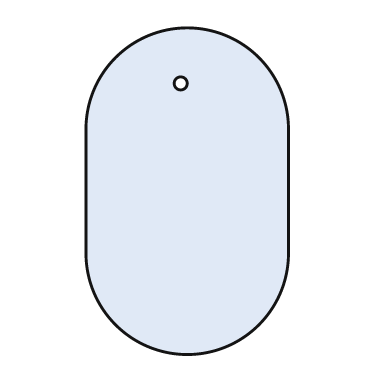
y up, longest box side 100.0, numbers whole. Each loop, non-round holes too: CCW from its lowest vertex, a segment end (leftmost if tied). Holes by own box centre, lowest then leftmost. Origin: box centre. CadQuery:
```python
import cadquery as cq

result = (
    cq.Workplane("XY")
    .moveTo(-31.0, -19.0)
    .threePointArc((0.0, -50.0), (31.0, -19.0))
    .lineTo(31.0, 19.0)
    .threePointArc((0.0, 50.0), (-31.0, 19.0))
    .close()
    .moveTo(-2.0, 33.0)
    .circle(2.0)
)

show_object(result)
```